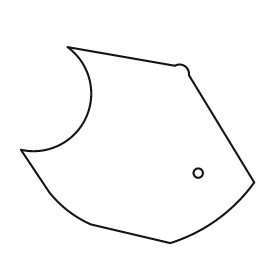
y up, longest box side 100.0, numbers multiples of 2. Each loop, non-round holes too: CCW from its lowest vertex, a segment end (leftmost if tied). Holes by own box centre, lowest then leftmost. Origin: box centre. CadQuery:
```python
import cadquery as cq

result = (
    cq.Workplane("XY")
    .moveTo(14.0, -42.0)
    .threePointArc((34.0, -32.0), (50.0, -16.0))
    .lineTo(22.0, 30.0)
    .threePointArc((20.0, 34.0), (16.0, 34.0))
    .lineTo(-30.0, 42.0)
    .threePointArc((-22.0, 12.0), (-50.0, -2.0))
    .lineTo(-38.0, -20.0)
    .threePointArc((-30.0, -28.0), (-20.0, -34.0))
    .close()
    .moveTo(26.0, -12.0)
    .circle(2.0)
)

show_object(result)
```